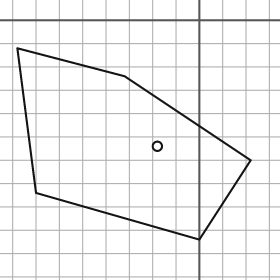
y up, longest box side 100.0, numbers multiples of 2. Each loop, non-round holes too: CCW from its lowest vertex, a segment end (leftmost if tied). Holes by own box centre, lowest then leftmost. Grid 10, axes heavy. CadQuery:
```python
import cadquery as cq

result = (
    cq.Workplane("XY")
    .moveTo(0.0, -94.0)
    .lineTo(22.0, -60.0)
    .lineTo(-32.0, -24.0)
    .lineTo(-78.0, -12.0)
    .lineTo(-70.0, -74.0)
    .close()
    .moveTo(-18.0, -54.0)
    .circle(2.0)
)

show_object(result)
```